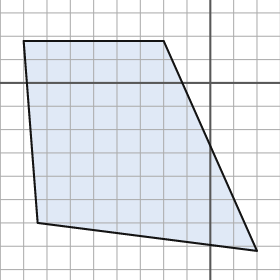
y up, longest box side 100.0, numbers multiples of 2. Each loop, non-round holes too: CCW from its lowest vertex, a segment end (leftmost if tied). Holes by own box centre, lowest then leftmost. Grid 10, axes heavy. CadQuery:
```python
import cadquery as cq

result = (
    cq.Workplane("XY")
    .moveTo(20.0, -72.0)
    .lineTo(-20.0, 18.0)
    .lineTo(-80.0, 18.0)
    .lineTo(-74.0, -60.0)
    .close()
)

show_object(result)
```